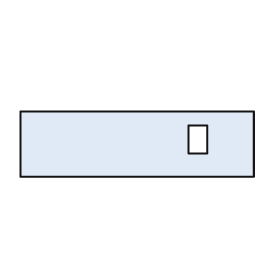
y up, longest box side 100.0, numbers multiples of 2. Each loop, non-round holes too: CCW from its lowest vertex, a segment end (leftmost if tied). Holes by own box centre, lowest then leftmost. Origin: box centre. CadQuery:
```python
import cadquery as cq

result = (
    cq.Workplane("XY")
    .moveTo(-50.0, -14.0)
    .lineTo(50.0, -14.0)
    .lineTo(50.0, 14.0)
    .lineTo(-50.0, 14.0)
    .close()
    .moveTo(22.0, -4.0)
    .lineTo(30.0, -4.0)
    .lineTo(30.0, 8.0)
    .lineTo(22.0, 8.0)
    .close()
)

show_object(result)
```